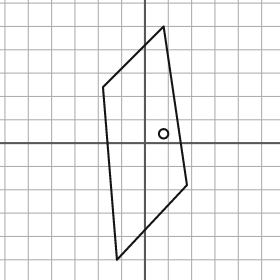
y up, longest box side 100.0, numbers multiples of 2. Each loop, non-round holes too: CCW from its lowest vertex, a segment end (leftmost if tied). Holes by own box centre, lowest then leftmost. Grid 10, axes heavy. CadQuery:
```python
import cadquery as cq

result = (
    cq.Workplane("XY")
    .moveTo(-12.0, -50.0)
    .lineTo(18.0, -18.0)
    .lineTo(8.0, 50.0)
    .lineTo(-18.0, 24.0)
    .close()
    .moveTo(8.0, 4.0)
    .circle(2.0)
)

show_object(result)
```